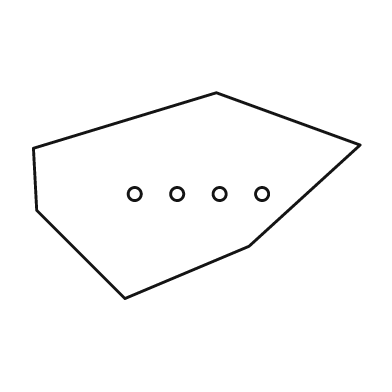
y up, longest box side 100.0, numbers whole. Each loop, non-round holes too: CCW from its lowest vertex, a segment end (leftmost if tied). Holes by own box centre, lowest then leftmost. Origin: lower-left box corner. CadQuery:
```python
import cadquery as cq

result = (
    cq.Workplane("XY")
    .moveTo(28.0, 0.0)
    .lineTo(66.0, 16.0)
    .lineTo(100.0, 47.0)
    .lineTo(56.0, 63.0)
    .lineTo(0.0, 46.0)
    .lineTo(1.0, 27.0)
    .close()
    .moveTo(31.0, 32.0)
    .circle(2.0)
    .moveTo(44.0, 32.0)
    .circle(2.0)
    .moveTo(57.0, 32.0)
    .circle(2.0)
    .moveTo(70.0, 32.0)
    .circle(2.0)
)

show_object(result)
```